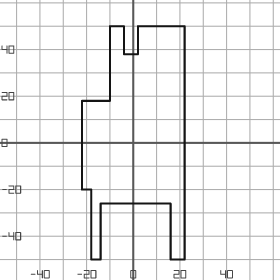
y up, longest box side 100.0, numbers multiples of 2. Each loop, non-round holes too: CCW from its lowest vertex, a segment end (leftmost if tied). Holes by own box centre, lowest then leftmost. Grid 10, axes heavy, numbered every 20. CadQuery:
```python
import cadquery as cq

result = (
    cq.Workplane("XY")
    .moveTo(-18.0, -50.0)
    .lineTo(-14.0, -50.0)
    .lineTo(-14.0, -26.0)
    .lineTo(16.0, -26.0)
    .lineTo(16.0, -50.0)
    .lineTo(22.0, -50.0)
    .lineTo(22.0, 50.0)
    .lineTo(2.0, 50.0)
    .lineTo(2.0, 38.0)
    .lineTo(-4.0, 38.0)
    .lineTo(-4.0, 50.0)
    .lineTo(-10.0, 50.0)
    .lineTo(-10.0, 18.0)
    .lineTo(-22.0, 18.0)
    .lineTo(-22.0, -20.0)
    .lineTo(-18.0, -20.0)
    .close()
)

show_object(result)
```